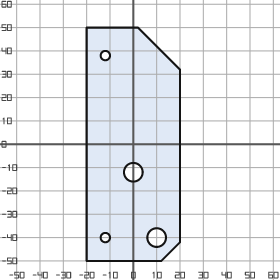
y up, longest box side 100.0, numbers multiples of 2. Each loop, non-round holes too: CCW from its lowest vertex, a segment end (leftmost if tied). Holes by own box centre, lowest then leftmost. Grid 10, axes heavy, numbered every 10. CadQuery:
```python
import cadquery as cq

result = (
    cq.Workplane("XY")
    .moveTo(-20.0, -50.0)
    .lineTo(12.0, -50.0)
    .lineTo(20.0, -42.0)
    .lineTo(20.0, 32.0)
    .lineTo(2.0, 50.0)
    .lineTo(-20.0, 50.0)
    .close()
    .moveTo(-12.0, -40.0)
    .circle(2.0)
    .moveTo(10.0, -40.0)
    .circle(4.0)
    .moveTo(0.0, -12.0)
    .circle(4.0)
    .moveTo(-12.0, 38.0)
    .circle(2.0)
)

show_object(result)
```